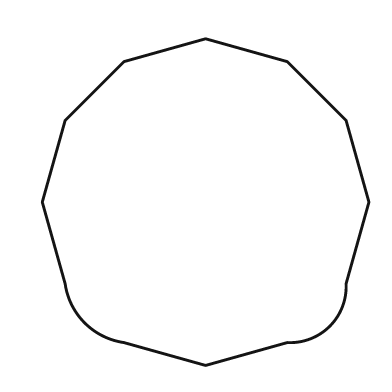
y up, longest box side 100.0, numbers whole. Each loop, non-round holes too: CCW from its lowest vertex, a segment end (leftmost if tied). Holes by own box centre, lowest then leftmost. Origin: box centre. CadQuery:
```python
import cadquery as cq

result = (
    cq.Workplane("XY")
    .moveTo(0.0, -50.0)
    .lineTo(25.0, -43.0)
    .threePointArc((38.0, -38.0), (43.0, -25.0))
    .lineTo(50.0, 0.0)
    .lineTo(43.0, 25.0)
    .lineTo(25.0, 43.0)
    .lineTo(0.0, 50.0)
    .lineTo(-25.0, 43.0)
    .lineTo(-43.0, 25.0)
    .lineTo(-50.0, 0.0)
    .lineTo(-43.0, -25.0)
    .threePointArc((-37.0, -37.0), (-25.0, -43.0))
    .close()
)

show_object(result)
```